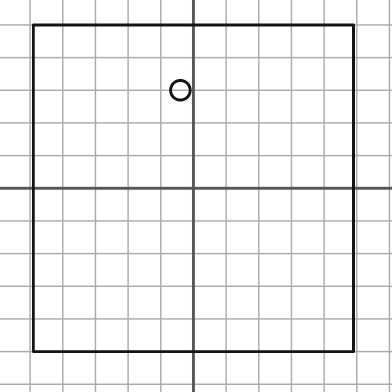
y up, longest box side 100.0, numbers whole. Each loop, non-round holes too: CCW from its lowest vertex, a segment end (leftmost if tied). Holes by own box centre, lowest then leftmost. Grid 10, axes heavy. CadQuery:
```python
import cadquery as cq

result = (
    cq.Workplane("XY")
    .moveTo(-49.0, -50.0)
    .lineTo(49.0, -50.0)
    .lineTo(49.0, 50.0)
    .lineTo(-49.0, 50.0)
    .close()
    .moveTo(-4.0, 30.0)
    .circle(3.0)
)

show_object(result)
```